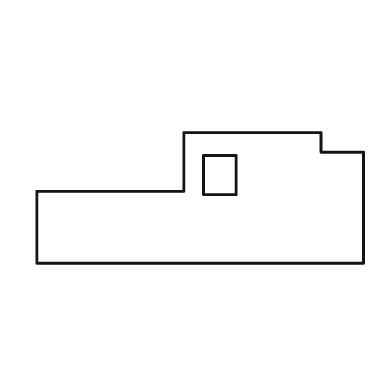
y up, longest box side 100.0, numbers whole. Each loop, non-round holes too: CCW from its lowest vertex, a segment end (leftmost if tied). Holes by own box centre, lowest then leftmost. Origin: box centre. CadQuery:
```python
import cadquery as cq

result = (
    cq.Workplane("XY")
    .moveTo(-50.0, -20.0)
    .lineTo(50.0, -20.0)
    .lineTo(50.0, 14.0)
    .lineTo(37.0, 14.0)
    .lineTo(37.0, 20.0)
    .lineTo(-5.0, 20.0)
    .lineTo(-5.0, 2.0)
    .lineTo(-50.0, 2.0)
    .close()
    .moveTo(1.0, 1.0)
    .lineTo(11.0, 1.0)
    .lineTo(11.0, 13.0)
    .lineTo(1.0, 13.0)
    .close()
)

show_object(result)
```